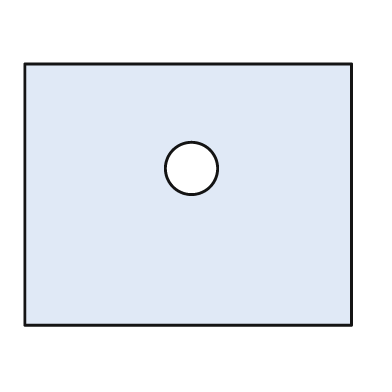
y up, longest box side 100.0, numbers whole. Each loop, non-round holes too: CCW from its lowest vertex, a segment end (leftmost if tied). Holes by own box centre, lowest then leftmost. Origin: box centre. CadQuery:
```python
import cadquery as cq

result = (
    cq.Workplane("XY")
    .moveTo(-50.0, -40.0)
    .lineTo(50.0, -40.0)
    .lineTo(50.0, 40.0)
    .lineTo(-50.0, 40.0)
    .close()
    .moveTo(1.0, 8.0)
    .circle(8.0)
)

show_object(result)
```